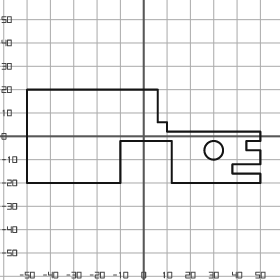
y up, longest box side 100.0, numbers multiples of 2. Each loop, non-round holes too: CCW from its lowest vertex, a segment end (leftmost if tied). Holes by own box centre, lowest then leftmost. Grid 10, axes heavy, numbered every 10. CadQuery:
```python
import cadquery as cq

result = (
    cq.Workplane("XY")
    .moveTo(-50.0, -20.0)
    .lineTo(-10.0, -20.0)
    .lineTo(-10.0, -2.0)
    .lineTo(12.0, -2.0)
    .lineTo(12.0, -20.0)
    .lineTo(50.0, -20.0)
    .lineTo(50.0, -16.0)
    .lineTo(38.0, -16.0)
    .lineTo(38.0, -12.0)
    .lineTo(50.0, -12.0)
    .lineTo(50.0, -6.0)
    .lineTo(44.0, -6.0)
    .lineTo(44.0, -2.0)
    .lineTo(50.0, -2.0)
    .lineTo(50.0, 2.0)
    .lineTo(10.0, 2.0)
    .lineTo(10.0, 6.0)
    .lineTo(6.0, 6.0)
    .lineTo(6.0, 20.0)
    .lineTo(-50.0, 20.0)
    .close()
    .moveTo(30.0, -6.0)
    .circle(4.0)
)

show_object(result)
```